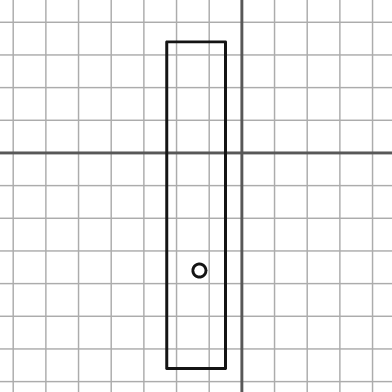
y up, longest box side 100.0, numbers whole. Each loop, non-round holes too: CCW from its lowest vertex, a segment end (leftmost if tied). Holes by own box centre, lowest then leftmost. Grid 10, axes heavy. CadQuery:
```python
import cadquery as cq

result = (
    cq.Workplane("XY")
    .moveTo(-23.0, -66.0)
    .lineTo(-5.0, -66.0)
    .lineTo(-5.0, 34.0)
    .lineTo(-23.0, 34.0)
    .close()
    .moveTo(-13.0, -36.0)
    .circle(2.0)
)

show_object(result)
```